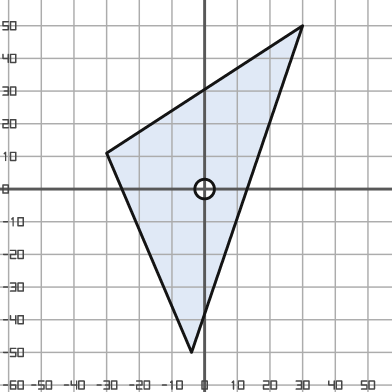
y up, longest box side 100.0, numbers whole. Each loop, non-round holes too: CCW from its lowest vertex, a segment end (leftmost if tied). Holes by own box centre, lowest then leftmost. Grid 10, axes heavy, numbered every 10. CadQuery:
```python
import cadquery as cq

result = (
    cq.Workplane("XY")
    .moveTo(-4.0, -50.0)
    .lineTo(30.0, 50.0)
    .lineTo(-30.0, 11.0)
    .close()
    .moveTo(0.0, 0.0)
    .circle(3.0)
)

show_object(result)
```